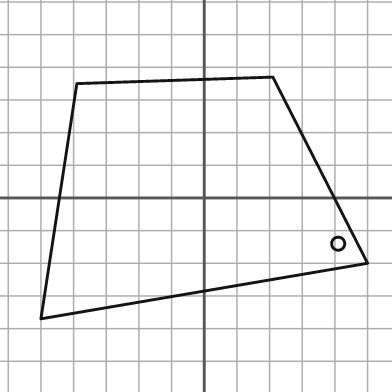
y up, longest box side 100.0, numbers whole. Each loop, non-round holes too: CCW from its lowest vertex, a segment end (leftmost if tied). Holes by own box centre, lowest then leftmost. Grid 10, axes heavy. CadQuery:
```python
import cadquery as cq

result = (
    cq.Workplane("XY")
    .moveTo(-50.0, -37.0)
    .lineTo(50.0, -20.0)
    .lineTo(21.0, 37.0)
    .lineTo(-39.0, 35.0)
    .close()
    .moveTo(41.0, -14.0)
    .circle(2.0)
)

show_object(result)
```